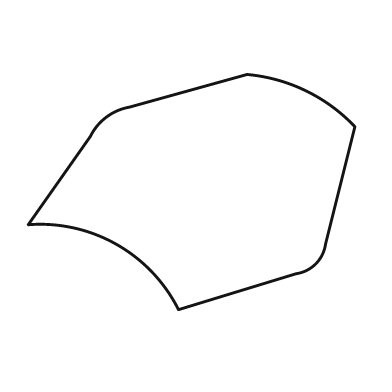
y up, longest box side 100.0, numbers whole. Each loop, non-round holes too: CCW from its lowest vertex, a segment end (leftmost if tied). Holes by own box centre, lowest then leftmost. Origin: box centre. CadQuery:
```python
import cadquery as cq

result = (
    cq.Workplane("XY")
    .moveTo(-4.0, -36.0)
    .lineTo(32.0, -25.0)
    .threePointArc((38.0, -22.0), (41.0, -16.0))
    .lineTo(50.0, 20.0)
    .threePointArc((35.0, 31.0), (17.0, 36.0))
    .lineTo(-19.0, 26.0)
    .threePointArc((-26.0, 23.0), (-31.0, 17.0))
    .lineTo(-50.0, -10.0)
    .threePointArc((-23.0, -16.0), (-4.0, -36.0))
    .close()
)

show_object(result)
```